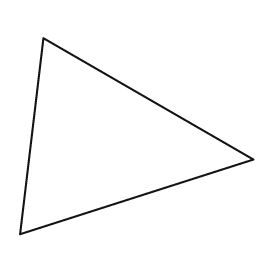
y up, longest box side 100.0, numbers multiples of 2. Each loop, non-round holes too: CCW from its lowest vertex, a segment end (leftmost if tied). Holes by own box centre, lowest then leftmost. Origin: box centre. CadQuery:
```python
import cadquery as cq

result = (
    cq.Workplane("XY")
    .moveTo(-50.0, -42.0)
    .lineTo(50.0, -10.0)
    .lineTo(-40.0, 42.0)
    .close()
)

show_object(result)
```